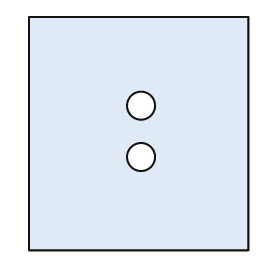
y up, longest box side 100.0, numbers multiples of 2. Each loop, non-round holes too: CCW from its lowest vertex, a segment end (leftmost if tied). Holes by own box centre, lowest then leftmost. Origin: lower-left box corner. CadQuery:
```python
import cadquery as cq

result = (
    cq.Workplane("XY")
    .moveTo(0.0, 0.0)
    .lineTo(94.0, 0.0)
    .lineTo(94.0, 100.0)
    .lineTo(0.0, 100.0)
    .close()
    .moveTo(48.0, 40.0)
    .circle(6.0)
    .moveTo(48.0, 62.0)
    .circle(6.0)
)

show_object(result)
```